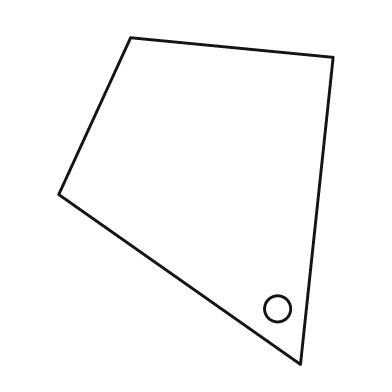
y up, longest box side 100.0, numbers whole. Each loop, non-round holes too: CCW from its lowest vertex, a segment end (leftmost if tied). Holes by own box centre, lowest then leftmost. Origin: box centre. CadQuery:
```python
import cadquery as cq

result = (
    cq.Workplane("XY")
    .moveTo(32.0, -50.0)
    .lineTo(42.0, 44.0)
    .lineTo(-20.0, 50.0)
    .lineTo(-42.0, 2.0)
    .close()
    .moveTo(25.0, -33.0)
    .circle(4.0)
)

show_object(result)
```